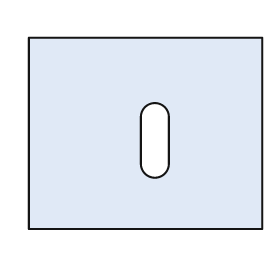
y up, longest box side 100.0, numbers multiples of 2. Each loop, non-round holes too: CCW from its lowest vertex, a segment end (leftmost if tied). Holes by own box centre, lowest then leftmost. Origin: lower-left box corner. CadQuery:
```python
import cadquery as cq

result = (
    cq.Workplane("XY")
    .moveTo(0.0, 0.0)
    .lineTo(100.0, 0.0)
    .lineTo(100.0, 82.0)
    .lineTo(0.0, 82.0)
    .close()
    .moveTo(48.0, 28.0)
    .threePointArc((54.0, 22.0), (60.0, 28.0))
    .lineTo(60.0, 48.0)
    .threePointArc((54.0, 54.0), (48.0, 48.0))
    .close()
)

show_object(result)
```